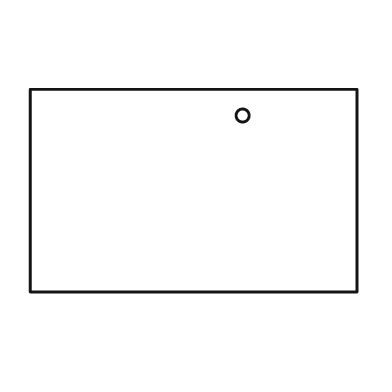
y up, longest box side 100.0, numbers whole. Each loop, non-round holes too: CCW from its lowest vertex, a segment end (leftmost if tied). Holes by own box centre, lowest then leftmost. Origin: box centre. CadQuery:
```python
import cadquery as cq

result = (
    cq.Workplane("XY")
    .moveTo(-50.0, -31.0)
    .lineTo(50.0, -31.0)
    .lineTo(50.0, 31.0)
    .lineTo(-50.0, 31.0)
    .close()
    .moveTo(15.0, 23.0)
    .circle(2.0)
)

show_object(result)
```